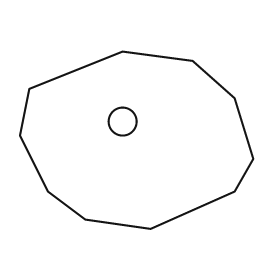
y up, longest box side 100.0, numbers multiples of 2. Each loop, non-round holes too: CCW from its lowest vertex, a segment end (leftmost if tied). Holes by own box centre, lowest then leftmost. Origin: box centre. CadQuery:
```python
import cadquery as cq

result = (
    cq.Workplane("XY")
    .moveTo(6.0, -38.0)
    .lineTo(42.0, -22.0)
    .lineTo(50.0, -8.0)
    .lineTo(42.0, 18.0)
    .lineTo(24.0, 34.0)
    .lineTo(-6.0, 38.0)
    .lineTo(-46.0, 22.0)
    .lineTo(-50.0, 2.0)
    .lineTo(-38.0, -22.0)
    .lineTo(-22.0, -34.0)
    .close()
    .moveTo(-6.0, 8.0)
    .circle(6.0)
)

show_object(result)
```